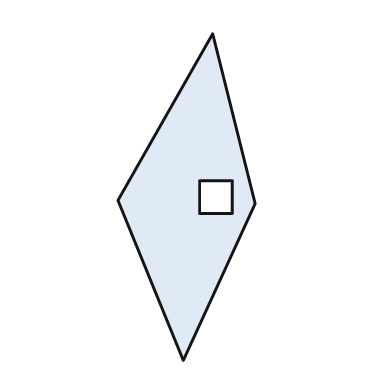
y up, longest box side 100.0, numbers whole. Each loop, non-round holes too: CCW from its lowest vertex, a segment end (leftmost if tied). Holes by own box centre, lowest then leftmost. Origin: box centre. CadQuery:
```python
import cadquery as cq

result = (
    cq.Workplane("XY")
    .moveTo(-1.0, -50.0)
    .lineTo(21.0, -2.0)
    .lineTo(8.0, 50.0)
    .lineTo(-21.0, -1.0)
    .close()
    .moveTo(4.0, -5.0)
    .lineTo(14.0, -5.0)
    .lineTo(14.0, 5.0)
    .lineTo(4.0, 5.0)
    .close()
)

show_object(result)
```